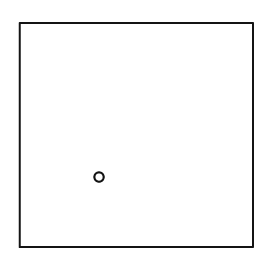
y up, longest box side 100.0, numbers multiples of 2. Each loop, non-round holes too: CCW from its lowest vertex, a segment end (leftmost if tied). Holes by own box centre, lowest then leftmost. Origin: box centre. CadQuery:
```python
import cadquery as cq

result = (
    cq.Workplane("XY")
    .moveTo(-50.0, -48.0)
    .lineTo(50.0, -48.0)
    .lineTo(50.0, 48.0)
    .lineTo(-50.0, 48.0)
    .close()
    .moveTo(-16.0, -18.0)
    .circle(2.0)
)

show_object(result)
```